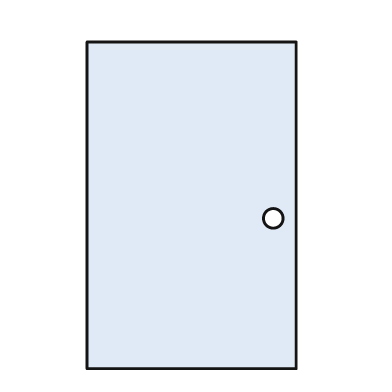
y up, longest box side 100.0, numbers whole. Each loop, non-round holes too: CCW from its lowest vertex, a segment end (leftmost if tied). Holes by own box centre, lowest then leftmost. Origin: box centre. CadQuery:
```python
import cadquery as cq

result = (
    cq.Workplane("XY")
    .moveTo(-32.0, -50.0)
    .lineTo(32.0, -50.0)
    .lineTo(32.0, 50.0)
    .lineTo(-32.0, 50.0)
    .close()
    .moveTo(25.0, -4.0)
    .circle(3.0)
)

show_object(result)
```